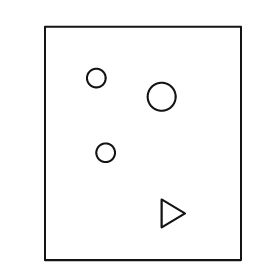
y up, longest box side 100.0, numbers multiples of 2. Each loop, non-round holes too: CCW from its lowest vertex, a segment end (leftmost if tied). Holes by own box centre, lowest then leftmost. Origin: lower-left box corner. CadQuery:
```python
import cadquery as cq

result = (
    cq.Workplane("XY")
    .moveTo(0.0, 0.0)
    .lineTo(84.0, 0.0)
    .lineTo(84.0, 100.0)
    .lineTo(0.0, 100.0)
    .close()
    .moveTo(50.0, 14.0)
    .lineTo(60.0, 20.0)
    .lineTo(50.0, 26.0)
    .close()
    .moveTo(26.0, 46.0)
    .circle(4.0)
    .moveTo(50.0, 70.0)
    .circle(6.0)
    .moveTo(22.0, 78.0)
    .circle(4.0)
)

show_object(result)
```